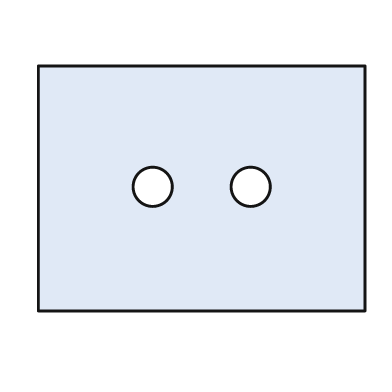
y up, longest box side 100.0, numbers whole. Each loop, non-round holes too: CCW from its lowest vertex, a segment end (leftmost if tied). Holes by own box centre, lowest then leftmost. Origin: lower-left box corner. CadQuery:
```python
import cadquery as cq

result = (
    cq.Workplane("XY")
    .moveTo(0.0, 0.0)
    .lineTo(100.0, 0.0)
    .lineTo(100.0, 75.0)
    .lineTo(0.0, 75.0)
    .close()
    .moveTo(35.0, 38.0)
    .circle(6.0)
    .moveTo(65.0, 38.0)
    .circle(6.0)
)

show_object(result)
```